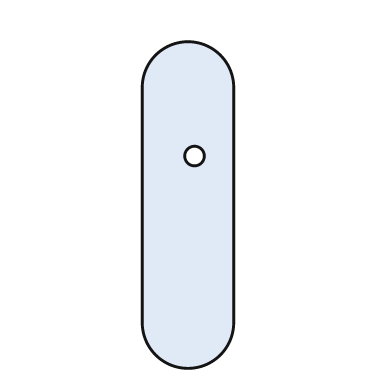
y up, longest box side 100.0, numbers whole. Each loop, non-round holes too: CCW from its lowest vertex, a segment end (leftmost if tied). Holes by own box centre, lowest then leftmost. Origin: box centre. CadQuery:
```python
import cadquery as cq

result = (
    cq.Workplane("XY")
    .moveTo(-14.0, -36.0)
    .threePointArc((0.0, -50.0), (14.0, -36.0))
    .lineTo(14.0, 36.0)
    .threePointArc((0.0, 50.0), (-14.0, 36.0))
    .close()
    .moveTo(2.0, 15.0)
    .circle(3.0)
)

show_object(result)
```